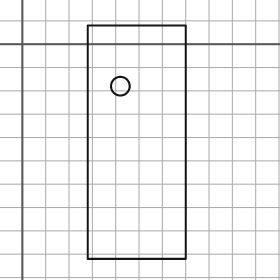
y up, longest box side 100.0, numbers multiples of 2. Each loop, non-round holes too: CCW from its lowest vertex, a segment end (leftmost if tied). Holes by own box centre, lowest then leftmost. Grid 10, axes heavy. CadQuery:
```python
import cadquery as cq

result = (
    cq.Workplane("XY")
    .moveTo(28.0, -92.0)
    .lineTo(70.0, -92.0)
    .lineTo(70.0, 8.0)
    .lineTo(28.0, 8.0)
    .close()
    .moveTo(42.0, -18.0)
    .circle(4.0)
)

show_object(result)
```